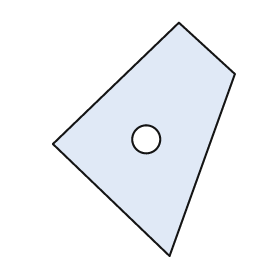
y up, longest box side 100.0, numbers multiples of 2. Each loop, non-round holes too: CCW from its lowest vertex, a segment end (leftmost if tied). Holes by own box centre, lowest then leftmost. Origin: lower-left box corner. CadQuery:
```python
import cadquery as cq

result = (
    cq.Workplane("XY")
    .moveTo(50.0, 0.0)
    .lineTo(78.0, 78.0)
    .lineTo(54.0, 100.0)
    .lineTo(0.0, 48.0)
    .close()
    .moveTo(40.0, 50.0)
    .circle(6.0)
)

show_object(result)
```